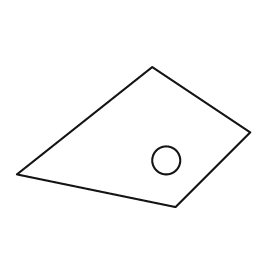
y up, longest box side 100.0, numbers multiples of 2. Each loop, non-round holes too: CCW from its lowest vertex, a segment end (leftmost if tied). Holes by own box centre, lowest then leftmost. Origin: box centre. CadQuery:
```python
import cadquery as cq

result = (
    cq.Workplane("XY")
    .moveTo(18.0, -30.0)
    .lineTo(50.0, 2.0)
    .lineTo(8.0, 30.0)
    .lineTo(-50.0, -16.0)
    .close()
    .moveTo(14.0, -10.0)
    .circle(6.0)
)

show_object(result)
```